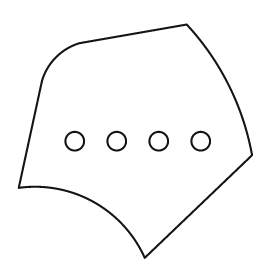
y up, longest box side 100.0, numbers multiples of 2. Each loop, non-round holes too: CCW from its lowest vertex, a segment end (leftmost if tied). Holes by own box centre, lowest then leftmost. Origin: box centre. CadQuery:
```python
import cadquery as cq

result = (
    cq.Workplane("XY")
    .moveTo(4.0, -50.0)
    .lineTo(50.0, -6.0)
    .threePointArc((40.0, 24.0), (22.0, 50.0))
    .lineTo(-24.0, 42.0)
    .threePointArc((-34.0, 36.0), (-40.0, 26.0))
    .lineTo(-50.0, -20.0)
    .threePointArc((-18.0, -26.0), (4.0, -50.0))
    .close()
    .moveTo(-26.0, 0.0)
    .circle(4.0)
    .moveTo(-8.0, 0.0)
    .circle(4.0)
    .moveTo(10.0, 0.0)
    .circle(4.0)
    .moveTo(28.0, 0.0)
    .circle(4.0)
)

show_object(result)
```